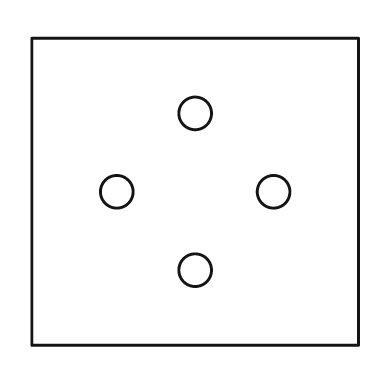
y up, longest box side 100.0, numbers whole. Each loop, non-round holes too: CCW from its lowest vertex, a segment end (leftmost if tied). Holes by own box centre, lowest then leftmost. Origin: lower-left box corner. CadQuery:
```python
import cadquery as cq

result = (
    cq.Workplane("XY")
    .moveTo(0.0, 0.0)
    .lineTo(100.0, 0.0)
    .lineTo(100.0, 94.0)
    .lineTo(0.0, 94.0)
    .close()
    .moveTo(50.0, 23.0)
    .circle(5.0)
    .moveTo(26.0, 47.0)
    .circle(5.0)
    .moveTo(74.0, 47.0)
    .circle(5.0)
    .moveTo(50.0, 71.0)
    .circle(5.0)
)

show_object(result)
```